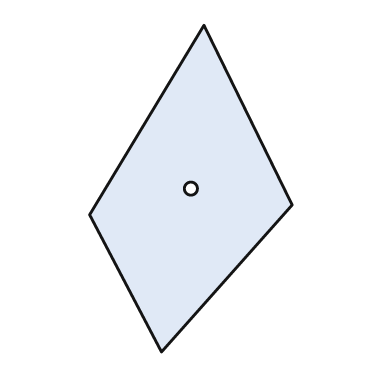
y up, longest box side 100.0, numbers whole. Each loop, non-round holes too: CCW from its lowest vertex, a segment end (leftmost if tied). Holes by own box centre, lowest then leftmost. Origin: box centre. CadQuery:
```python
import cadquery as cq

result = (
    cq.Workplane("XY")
    .moveTo(-9.0, -50.0)
    .lineTo(31.0, -5.0)
    .lineTo(4.0, 50.0)
    .lineTo(-31.0, -8.0)
    .close()
    .moveTo(0.0, 0.0)
    .circle(2.0)
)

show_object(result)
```